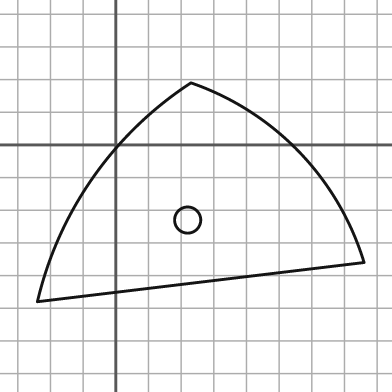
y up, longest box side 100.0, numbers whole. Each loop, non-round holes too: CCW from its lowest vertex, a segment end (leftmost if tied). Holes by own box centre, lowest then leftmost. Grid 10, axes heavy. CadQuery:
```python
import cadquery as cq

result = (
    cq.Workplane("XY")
    .moveTo(-24.0, -48.0)
    .lineTo(76.0, -36.0)
    .threePointArc((56.0, -2.0), (23.0, 19.0))
    .threePointArc((-7.0, -10.0), (-24.0, -48.0))
    .close()
    .moveTo(22.0, -23.0)
    .circle(4.0)
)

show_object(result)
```